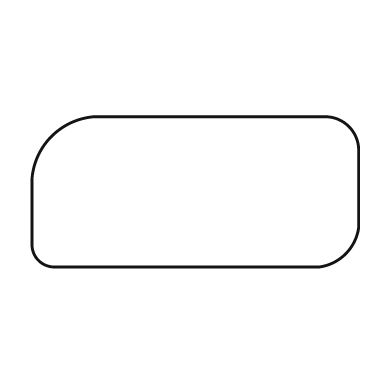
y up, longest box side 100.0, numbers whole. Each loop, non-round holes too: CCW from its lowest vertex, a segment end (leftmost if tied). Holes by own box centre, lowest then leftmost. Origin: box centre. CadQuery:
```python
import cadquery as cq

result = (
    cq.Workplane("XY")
    .moveTo(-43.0, -23.0)
    .lineTo(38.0, -23.0)
    .threePointArc((46.0, -19.0), (50.0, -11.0))
    .lineTo(50.0, 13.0)
    .threePointArc((47.0, 20.0), (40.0, 23.0))
    .lineTo(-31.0, 23.0)
    .threePointArc((-44.0, 17.0), (-50.0, 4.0))
    .lineTo(-50.0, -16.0)
    .threePointArc((-48.0, -21.0), (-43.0, -23.0))
    .close()
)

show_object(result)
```